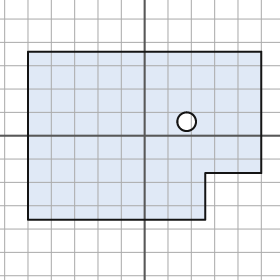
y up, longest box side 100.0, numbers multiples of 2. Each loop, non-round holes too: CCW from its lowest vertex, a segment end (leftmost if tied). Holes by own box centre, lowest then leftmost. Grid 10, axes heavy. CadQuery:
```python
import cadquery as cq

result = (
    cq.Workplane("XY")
    .moveTo(-50.0, -36.0)
    .lineTo(26.0, -36.0)
    .lineTo(26.0, -16.0)
    .lineTo(50.0, -16.0)
    .lineTo(50.0, 36.0)
    .lineTo(-50.0, 36.0)
    .close()
    .moveTo(18.0, 6.0)
    .circle(4.0)
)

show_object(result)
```